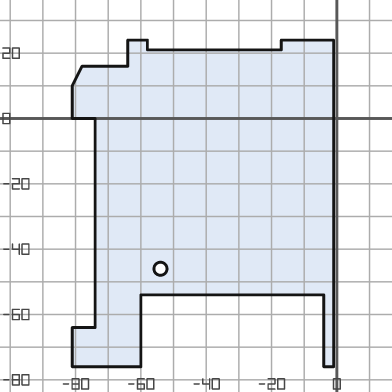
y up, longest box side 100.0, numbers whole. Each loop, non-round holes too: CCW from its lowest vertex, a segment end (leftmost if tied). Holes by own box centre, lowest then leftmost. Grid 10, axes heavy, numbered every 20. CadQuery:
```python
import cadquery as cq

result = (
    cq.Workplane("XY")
    .moveTo(-81.0, -76.0)
    .lineTo(-60.0, -76.0)
    .lineTo(-60.0, -54.0)
    .lineTo(-4.0, -54.0)
    .lineTo(-4.0, -76.0)
    .lineTo(-1.0, -76.0)
    .lineTo(-1.0, 24.0)
    .lineTo(-17.0, 24.0)
    .lineTo(-17.0, 21.0)
    .lineTo(-58.0, 21.0)
    .lineTo(-58.0, 24.0)
    .lineTo(-64.0, 24.0)
    .lineTo(-64.0, 16.0)
    .lineTo(-78.0, 16.0)
    .lineTo(-81.0, 10.0)
    .lineTo(-81.0, 0.0)
    .lineTo(-74.0, 0.0)
    .lineTo(-74.0, -64.0)
    .lineTo(-81.0, -64.0)
    .close()
    .moveTo(-54.0, -46.0)
    .circle(2.0)
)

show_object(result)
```